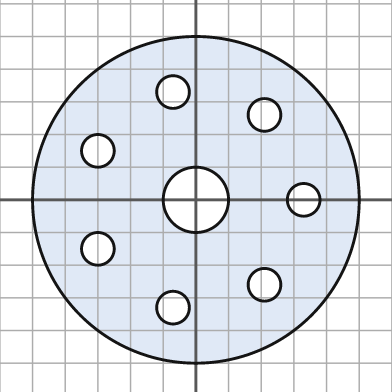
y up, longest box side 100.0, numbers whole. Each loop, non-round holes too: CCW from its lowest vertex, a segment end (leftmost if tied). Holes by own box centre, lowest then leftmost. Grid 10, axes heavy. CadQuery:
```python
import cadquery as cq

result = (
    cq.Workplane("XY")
    .moveTo(0.0, 0.0)
    .circle(50.0)
    .moveTo(-7.0, -33.0)
    .circle(5.0)
    .moveTo(21.0, -26.0)
    .circle(5.0)
    .moveTo(-30.0, -15.0)
    .circle(5.0)
    .moveTo(0.0, 0.0)
    .circle(10.0)
    .moveTo(33.0, 0.0)
    .circle(5.0)
    .moveTo(-30.0, 15.0)
    .circle(5.0)
    .moveTo(21.0, 26.0)
    .circle(5.0)
    .moveTo(-7.0, 33.0)
    .circle(5.0)
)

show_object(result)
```